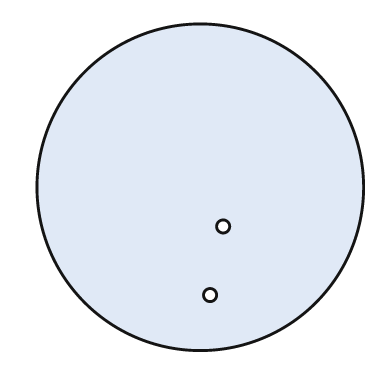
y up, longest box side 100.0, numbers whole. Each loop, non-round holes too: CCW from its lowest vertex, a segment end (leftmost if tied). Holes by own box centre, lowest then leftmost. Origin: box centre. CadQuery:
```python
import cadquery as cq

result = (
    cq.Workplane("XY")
    .moveTo(0.0, 0.0)
    .circle(50.0)
    .moveTo(3.0, -33.0)
    .circle(2.0)
    .moveTo(7.0, -12.0)
    .circle(2.0)
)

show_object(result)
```